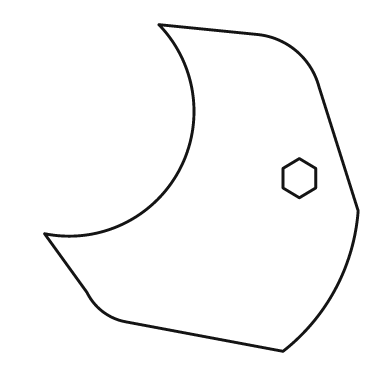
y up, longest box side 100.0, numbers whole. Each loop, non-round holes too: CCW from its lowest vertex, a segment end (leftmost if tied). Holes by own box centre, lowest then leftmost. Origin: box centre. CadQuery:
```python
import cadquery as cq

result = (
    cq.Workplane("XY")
    .moveTo(25.0, -50.0)
    .threePointArc((41.0, -31.0), (48.0, -7.0))
    .lineTo(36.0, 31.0)
    .threePointArc((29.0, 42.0), (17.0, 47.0))
    .lineTo(-13.0, 50.0)
    .threePointArc((-7.0, 5.0), (-48.0, -14.0))
    .lineTo(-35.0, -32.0)
    .threePointArc((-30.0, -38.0), (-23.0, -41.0))
    .close()
    .moveTo(30.0, -3.0)
    .lineTo(35.0, 0.0)
    .lineTo(35.0, 6.0)
    .lineTo(30.0, 9.0)
    .lineTo(25.0, 6.0)
    .lineTo(25.0, 0.0)
    .close()
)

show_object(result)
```